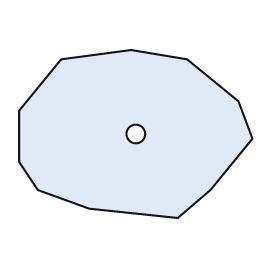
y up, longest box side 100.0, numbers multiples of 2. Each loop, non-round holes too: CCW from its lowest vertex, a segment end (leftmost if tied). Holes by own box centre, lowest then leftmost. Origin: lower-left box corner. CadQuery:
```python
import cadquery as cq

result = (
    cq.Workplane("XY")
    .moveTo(68.0, 0.0)
    .lineTo(82.0, 12.0)
    .lineTo(100.0, 34.0)
    .lineTo(94.0, 50.0)
    .lineTo(72.0, 68.0)
    .lineTo(48.0, 72.0)
    .lineTo(18.0, 68.0)
    .lineTo(0.0, 46.0)
    .lineTo(0.0, 24.0)
    .lineTo(8.0, 12.0)
    .lineTo(30.0, 4.0)
    .close()
    .moveTo(50.0, 36.0)
    .circle(4.0)
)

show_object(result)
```